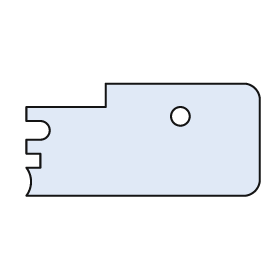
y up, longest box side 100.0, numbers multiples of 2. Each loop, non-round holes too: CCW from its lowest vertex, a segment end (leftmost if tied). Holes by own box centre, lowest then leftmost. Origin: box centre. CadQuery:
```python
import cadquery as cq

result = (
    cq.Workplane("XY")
    .moveTo(-50.0, -24.0)
    .lineTo(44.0, -24.0)
    .threePointArc((48.0, -22.0), (50.0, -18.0))
    .lineTo(50.0, 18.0)
    .threePointArc((48.0, 22.0), (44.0, 24.0))
    .lineTo(-16.0, 24.0)
    .lineTo(-16.0, 14.0)
    .lineTo(-50.0, 14.0)
    .lineTo(-50.0, 8.0)
    .lineTo(-44.0, 8.0)
    .threePointArc((-40.0, 4.0), (-44.0, 0.0))
    .lineTo(-50.0, 0.0)
    .lineTo(-50.0, -6.0)
    .lineTo(-44.0, -6.0)
    .lineTo(-44.0, -12.0)
    .lineTo(-50.0, -12.0)
    .threePointArc((-48.0, -18.0), (-50.0, -24.0))
    .close()
    .moveTo(16.0, 10.0)
    .circle(4.0)
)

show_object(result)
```